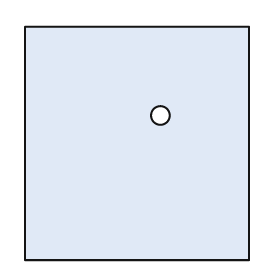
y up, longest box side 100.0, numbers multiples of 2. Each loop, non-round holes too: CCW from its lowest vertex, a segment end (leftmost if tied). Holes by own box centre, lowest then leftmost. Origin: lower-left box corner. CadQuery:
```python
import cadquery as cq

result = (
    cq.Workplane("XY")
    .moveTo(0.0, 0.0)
    .lineTo(96.0, 0.0)
    .lineTo(96.0, 100.0)
    .lineTo(0.0, 100.0)
    .close()
    .moveTo(58.0, 62.0)
    .circle(4.0)
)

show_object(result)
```